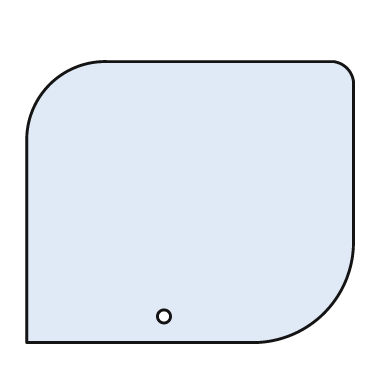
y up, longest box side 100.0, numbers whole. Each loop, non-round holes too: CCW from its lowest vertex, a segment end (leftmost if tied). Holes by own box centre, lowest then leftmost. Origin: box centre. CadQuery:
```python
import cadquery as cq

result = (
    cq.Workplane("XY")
    .moveTo(-50.0, -43.0)
    .lineTo(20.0, -43.0)
    .threePointArc((41.0, -34.0), (50.0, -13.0))
    .lineTo(50.0, 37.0)
    .threePointArc((48.0, 41.0), (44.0, 43.0))
    .lineTo(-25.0, 43.0)
    .threePointArc((-43.0, 36.0), (-50.0, 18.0))
    .close()
    .moveTo(-8.0, -35.0)
    .circle(2.0)
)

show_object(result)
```